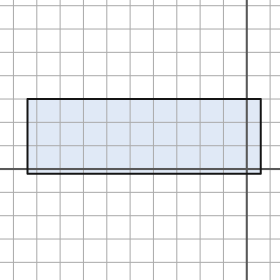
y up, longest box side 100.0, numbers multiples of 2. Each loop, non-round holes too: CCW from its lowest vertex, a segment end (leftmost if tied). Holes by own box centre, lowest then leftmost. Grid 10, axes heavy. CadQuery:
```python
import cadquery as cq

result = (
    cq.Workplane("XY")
    .moveTo(-94.0, -2.0)
    .lineTo(6.0, -2.0)
    .lineTo(6.0, 30.0)
    .lineTo(-94.0, 30.0)
    .close()
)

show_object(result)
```